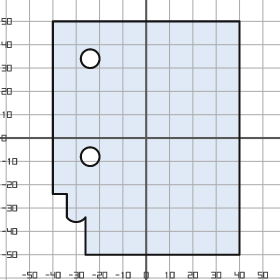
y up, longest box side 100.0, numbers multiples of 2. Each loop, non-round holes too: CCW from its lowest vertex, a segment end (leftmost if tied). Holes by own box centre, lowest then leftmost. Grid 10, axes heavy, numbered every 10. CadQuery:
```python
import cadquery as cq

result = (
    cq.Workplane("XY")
    .moveTo(-26.0, -50.0)
    .lineTo(40.0, -50.0)
    .lineTo(40.0, 50.0)
    .lineTo(-40.0, 50.0)
    .lineTo(-40.0, -24.0)
    .lineTo(-34.0, -24.0)
    .lineTo(-34.0, -34.0)
    .threePointArc((-30.0, -36.0), (-26.0, -34.0))
    .close()
    .moveTo(-24.0, -8.0)
    .circle(4.0)
    .moveTo(-24.0, 34.0)
    .circle(4.0)
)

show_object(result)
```